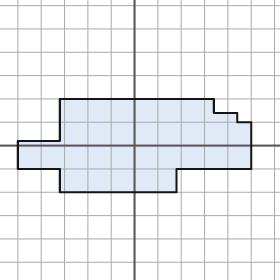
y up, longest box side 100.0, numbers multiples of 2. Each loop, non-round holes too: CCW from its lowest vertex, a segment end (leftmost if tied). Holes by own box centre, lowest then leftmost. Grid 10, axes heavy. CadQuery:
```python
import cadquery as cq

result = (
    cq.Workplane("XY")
    .moveTo(-32.0, -20.0)
    .lineTo(18.0, -20.0)
    .lineTo(18.0, -10.0)
    .lineTo(50.0, -10.0)
    .lineTo(50.0, 10.0)
    .lineTo(44.0, 10.0)
    .lineTo(44.0, 14.0)
    .lineTo(34.0, 14.0)
    .lineTo(34.0, 20.0)
    .lineTo(-32.0, 20.0)
    .lineTo(-32.0, 2.0)
    .lineTo(-50.0, 2.0)
    .lineTo(-50.0, -10.0)
    .lineTo(-32.0, -10.0)
    .close()
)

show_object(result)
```